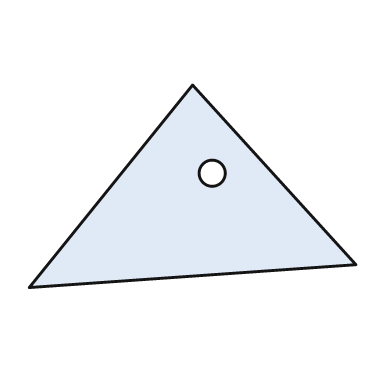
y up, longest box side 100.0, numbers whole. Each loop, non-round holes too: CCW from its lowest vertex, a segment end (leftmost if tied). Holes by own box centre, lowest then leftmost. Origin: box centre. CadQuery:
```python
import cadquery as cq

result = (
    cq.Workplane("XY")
    .moveTo(-50.0, -31.0)
    .lineTo(50.0, -24.0)
    .lineTo(0.0, 31.0)
    .close()
    .moveTo(6.0, 4.0)
    .circle(4.0)
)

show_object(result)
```